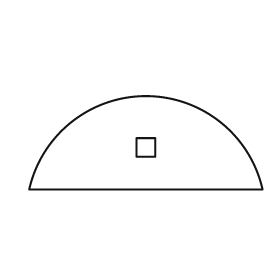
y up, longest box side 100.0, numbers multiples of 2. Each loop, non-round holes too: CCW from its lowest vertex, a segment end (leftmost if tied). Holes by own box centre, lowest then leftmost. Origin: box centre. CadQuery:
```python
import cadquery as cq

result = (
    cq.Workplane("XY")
    .moveTo(-50.0, -20.0)
    .lineTo(50.0, -20.0)
    .threePointArc((0.0, 20.0), (-50.0, -20.0))
    .close()
    .moveTo(-4.0, -6.0)
    .lineTo(4.0, -6.0)
    .lineTo(4.0, 2.0)
    .lineTo(-4.0, 2.0)
    .close()
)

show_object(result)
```